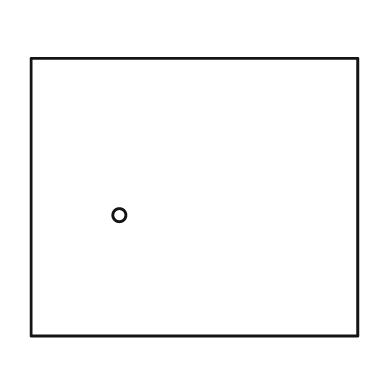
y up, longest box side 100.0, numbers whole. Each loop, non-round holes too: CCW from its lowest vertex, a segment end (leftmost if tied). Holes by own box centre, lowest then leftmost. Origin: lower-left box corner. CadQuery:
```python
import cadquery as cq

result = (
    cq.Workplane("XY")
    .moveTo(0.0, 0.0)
    .lineTo(100.0, 0.0)
    .lineTo(100.0, 85.0)
    .lineTo(0.0, 85.0)
    .close()
    .moveTo(27.0, 37.0)
    .circle(2.0)
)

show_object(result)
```